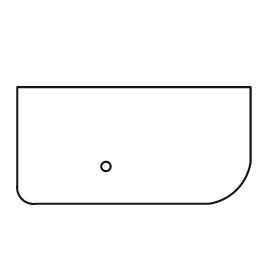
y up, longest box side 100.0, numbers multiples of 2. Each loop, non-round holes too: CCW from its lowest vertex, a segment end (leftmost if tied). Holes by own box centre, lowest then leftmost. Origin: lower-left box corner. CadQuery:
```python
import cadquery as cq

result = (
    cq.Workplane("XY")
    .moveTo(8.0, 0.0)
    .lineTo(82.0, 0.0)
    .threePointArc((94.0, 6.0), (100.0, 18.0))
    .lineTo(100.0, 50.0)
    .lineTo(0.0, 50.0)
    .lineTo(0.0, 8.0)
    .threePointArc((2.0, 2.0), (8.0, 0.0))
    .close()
    .moveTo(38.0, 16.0)
    .circle(2.0)
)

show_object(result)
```